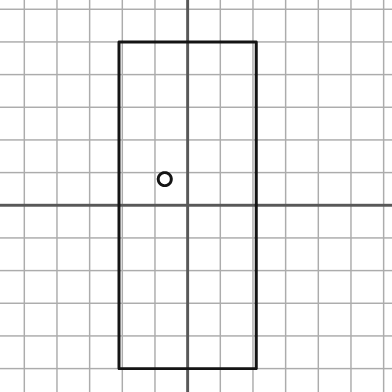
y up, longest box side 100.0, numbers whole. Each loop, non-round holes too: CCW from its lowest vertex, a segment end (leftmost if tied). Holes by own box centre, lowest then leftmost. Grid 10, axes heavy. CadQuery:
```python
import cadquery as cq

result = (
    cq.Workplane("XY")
    .moveTo(-21.0, -50.0)
    .lineTo(21.0, -50.0)
    .lineTo(21.0, 50.0)
    .lineTo(-21.0, 50.0)
    .close()
    .moveTo(-7.0, 8.0)
    .circle(2.0)
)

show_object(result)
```